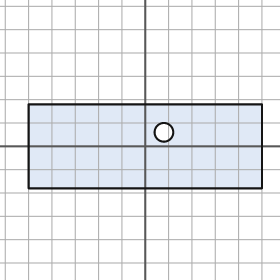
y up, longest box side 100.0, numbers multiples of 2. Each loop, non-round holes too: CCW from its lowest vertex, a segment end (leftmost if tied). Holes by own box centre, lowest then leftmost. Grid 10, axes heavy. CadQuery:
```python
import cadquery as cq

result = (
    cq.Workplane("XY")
    .moveTo(-50.0, -18.0)
    .lineTo(50.0, -18.0)
    .lineTo(50.0, 18.0)
    .lineTo(-50.0, 18.0)
    .close()
    .moveTo(8.0, 6.0)
    .circle(4.0)
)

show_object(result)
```